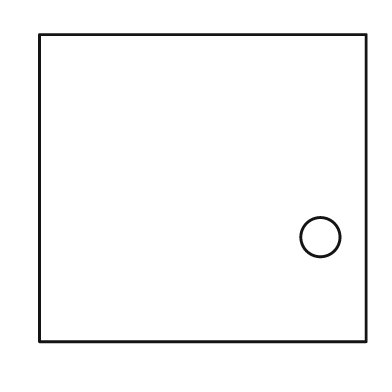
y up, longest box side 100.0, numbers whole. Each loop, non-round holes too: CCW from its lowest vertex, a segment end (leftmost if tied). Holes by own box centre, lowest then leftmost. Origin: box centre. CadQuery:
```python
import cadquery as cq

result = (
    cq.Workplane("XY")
    .moveTo(-50.0, -47.0)
    .lineTo(50.0, -47.0)
    .lineTo(50.0, 47.0)
    .lineTo(-50.0, 47.0)
    .close()
    .moveTo(36.0, -15.0)
    .circle(6.0)
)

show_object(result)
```